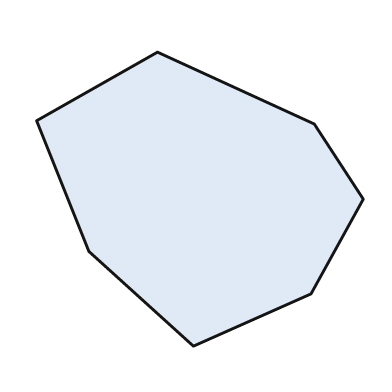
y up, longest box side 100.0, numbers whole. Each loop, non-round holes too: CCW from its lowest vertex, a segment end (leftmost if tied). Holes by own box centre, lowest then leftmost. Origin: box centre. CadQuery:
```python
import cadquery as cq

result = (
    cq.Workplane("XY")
    .moveTo(-2.0, -45.0)
    .lineTo(34.0, -29.0)
    .lineTo(50.0, 0.0)
    .lineTo(35.0, 23.0)
    .lineTo(-13.0, 45.0)
    .lineTo(-50.0, 24.0)
    .lineTo(-34.0, -16.0)
    .close()
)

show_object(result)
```